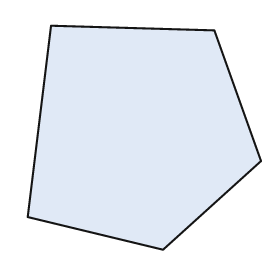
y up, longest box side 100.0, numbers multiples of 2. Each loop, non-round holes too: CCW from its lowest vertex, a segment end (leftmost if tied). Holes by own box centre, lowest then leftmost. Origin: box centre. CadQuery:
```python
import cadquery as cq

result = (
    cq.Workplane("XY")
    .moveTo(8.0, -48.0)
    .lineTo(50.0, -10.0)
    .lineTo(30.0, 46.0)
    .lineTo(-40.0, 48.0)
    .lineTo(-50.0, -34.0)
    .close()
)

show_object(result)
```